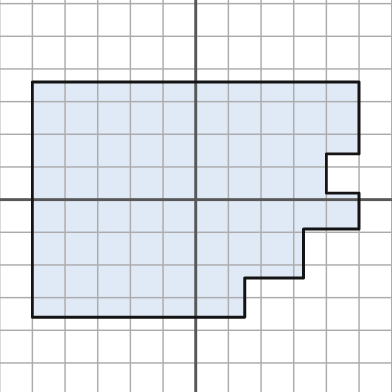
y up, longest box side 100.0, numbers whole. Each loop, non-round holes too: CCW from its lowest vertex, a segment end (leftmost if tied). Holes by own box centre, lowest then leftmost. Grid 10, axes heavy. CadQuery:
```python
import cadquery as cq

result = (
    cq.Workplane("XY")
    .moveTo(-50.0, -36.0)
    .lineTo(15.0, -36.0)
    .lineTo(15.0, -24.0)
    .lineTo(33.0, -24.0)
    .lineTo(33.0, -9.0)
    .lineTo(50.0, -9.0)
    .lineTo(50.0, 2.0)
    .lineTo(40.0, 2.0)
    .lineTo(40.0, 14.0)
    .lineTo(50.0, 14.0)
    .lineTo(50.0, 36.0)
    .lineTo(-50.0, 36.0)
    .close()
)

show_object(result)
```